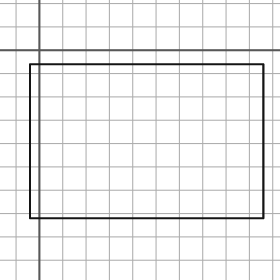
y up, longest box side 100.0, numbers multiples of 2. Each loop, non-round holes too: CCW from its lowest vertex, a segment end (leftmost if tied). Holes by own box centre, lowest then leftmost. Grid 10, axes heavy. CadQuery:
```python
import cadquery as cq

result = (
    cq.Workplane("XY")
    .moveTo(-4.0, -72.0)
    .lineTo(96.0, -72.0)
    .lineTo(96.0, -6.0)
    .lineTo(-4.0, -6.0)
    .close()
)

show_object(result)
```